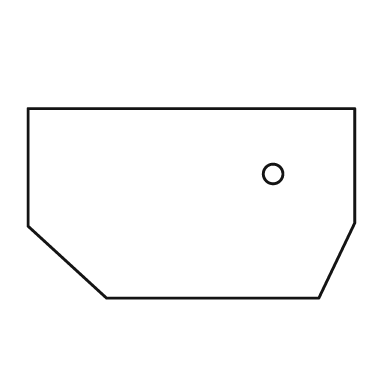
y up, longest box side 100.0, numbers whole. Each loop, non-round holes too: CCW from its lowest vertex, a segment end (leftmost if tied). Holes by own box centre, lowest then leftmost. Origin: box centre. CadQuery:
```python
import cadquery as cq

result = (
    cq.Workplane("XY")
    .moveTo(-26.0, -29.0)
    .lineTo(39.0, -29.0)
    .lineTo(50.0, -6.0)
    .lineTo(50.0, 29.0)
    .lineTo(-50.0, 29.0)
    .lineTo(-50.0, -7.0)
    .close()
    .moveTo(25.0, 9.0)
    .circle(3.0)
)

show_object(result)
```